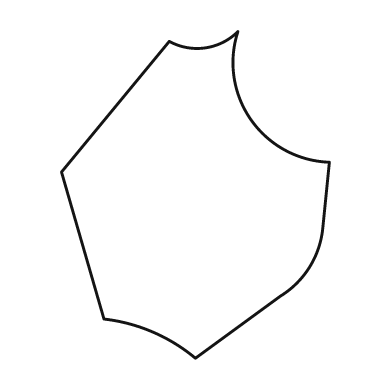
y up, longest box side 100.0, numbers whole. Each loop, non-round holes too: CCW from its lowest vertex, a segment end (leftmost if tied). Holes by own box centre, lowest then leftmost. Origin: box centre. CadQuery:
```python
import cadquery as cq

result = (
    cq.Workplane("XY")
    .moveTo(0.0, -50.0)
    .lineTo(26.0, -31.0)
    .threePointArc((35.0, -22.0), (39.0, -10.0))
    .lineTo(41.0, 10.0)
    .threePointArc((17.0, 23.0), (13.0, 50.0))
    .threePointArc((3.0, 45.0), (-8.0, 47.0))
    .lineTo(-41.0, 7.0)
    .lineTo(-28.0, -38.0)
    .threePointArc((-13.0, -42.0), (0.0, -50.0))
    .close()
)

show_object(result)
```